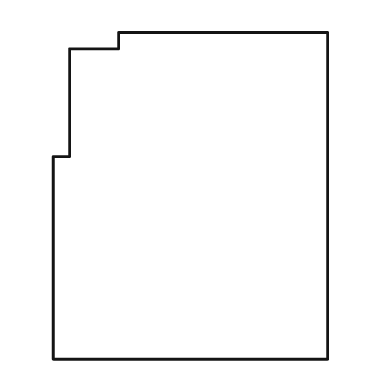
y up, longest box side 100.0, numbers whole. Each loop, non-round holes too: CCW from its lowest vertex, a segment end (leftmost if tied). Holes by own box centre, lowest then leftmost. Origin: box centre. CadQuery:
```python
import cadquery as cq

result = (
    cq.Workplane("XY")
    .moveTo(-42.0, -50.0)
    .lineTo(42.0, -50.0)
    .lineTo(42.0, 50.0)
    .lineTo(-22.0, 50.0)
    .lineTo(-22.0, 45.0)
    .lineTo(-37.0, 45.0)
    .lineTo(-37.0, 12.0)
    .lineTo(-42.0, 12.0)
    .close()
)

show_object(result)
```